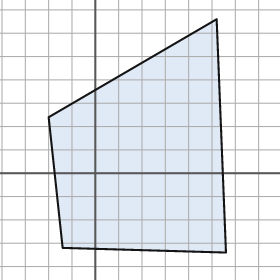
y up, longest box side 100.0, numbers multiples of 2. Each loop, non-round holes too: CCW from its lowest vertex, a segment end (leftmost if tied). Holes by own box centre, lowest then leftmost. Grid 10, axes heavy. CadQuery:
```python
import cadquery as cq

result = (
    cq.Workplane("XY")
    .moveTo(56.0, -34.0)
    .lineTo(52.0, 66.0)
    .lineTo(-20.0, 24.0)
    .lineTo(-14.0, -32.0)
    .close()
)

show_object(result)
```